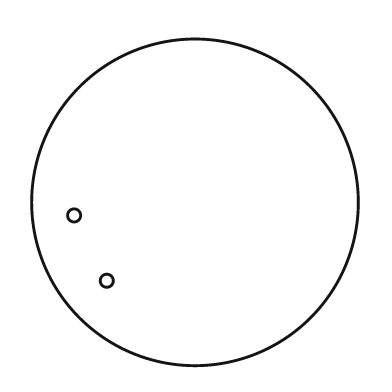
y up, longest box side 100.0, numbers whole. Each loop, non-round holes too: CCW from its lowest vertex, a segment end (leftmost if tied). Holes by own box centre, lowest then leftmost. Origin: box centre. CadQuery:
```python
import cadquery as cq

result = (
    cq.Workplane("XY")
    .moveTo(0.0, 0.0)
    .circle(50.0)
    .moveTo(-27.0, -24.0)
    .circle(2.0)
    .moveTo(-37.0, -4.0)
    .circle(2.0)
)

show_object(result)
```